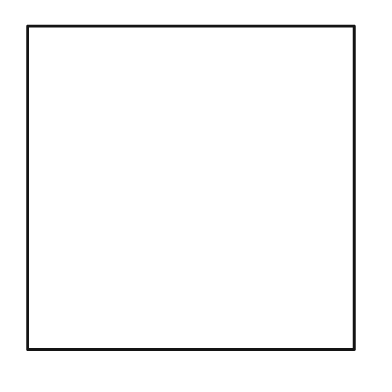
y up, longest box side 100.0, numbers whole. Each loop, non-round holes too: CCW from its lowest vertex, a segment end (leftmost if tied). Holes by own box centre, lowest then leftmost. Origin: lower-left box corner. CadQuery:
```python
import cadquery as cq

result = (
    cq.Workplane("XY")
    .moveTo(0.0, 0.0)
    .lineTo(100.0, 0.0)
    .lineTo(100.0, 99.0)
    .lineTo(0.0, 99.0)
    .close()
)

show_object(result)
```